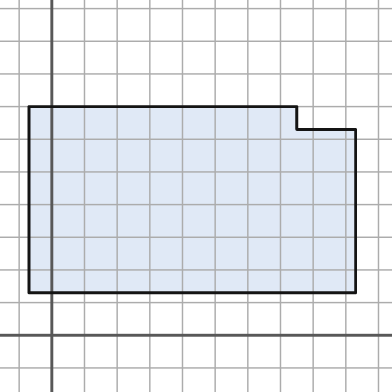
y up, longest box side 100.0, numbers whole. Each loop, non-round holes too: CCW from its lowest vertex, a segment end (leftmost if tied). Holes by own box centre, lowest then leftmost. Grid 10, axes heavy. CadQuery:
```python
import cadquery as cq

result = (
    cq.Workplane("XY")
    .moveTo(-7.0, 13.0)
    .lineTo(93.0, 13.0)
    .lineTo(93.0, 63.0)
    .lineTo(75.0, 63.0)
    .lineTo(75.0, 70.0)
    .lineTo(-7.0, 70.0)
    .close()
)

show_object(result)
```